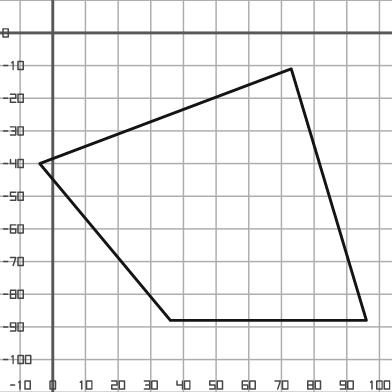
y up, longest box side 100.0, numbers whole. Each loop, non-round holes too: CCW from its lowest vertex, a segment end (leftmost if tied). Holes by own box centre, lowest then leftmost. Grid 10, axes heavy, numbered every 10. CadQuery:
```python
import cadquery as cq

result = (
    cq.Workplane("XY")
    .moveTo(36.0, -88.0)
    .lineTo(96.0, -88.0)
    .lineTo(73.0, -11.0)
    .lineTo(-4.0, -40.0)
    .close()
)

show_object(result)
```